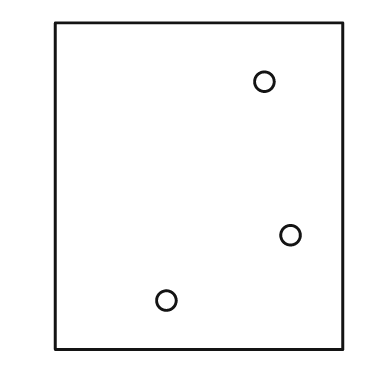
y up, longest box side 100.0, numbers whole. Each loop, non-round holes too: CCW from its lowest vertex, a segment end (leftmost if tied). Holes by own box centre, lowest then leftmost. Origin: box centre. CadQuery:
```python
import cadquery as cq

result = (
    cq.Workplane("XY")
    .moveTo(-44.0, -50.0)
    .lineTo(44.0, -50.0)
    .lineTo(44.0, 50.0)
    .lineTo(-44.0, 50.0)
    .close()
    .moveTo(-10.0, -35.0)
    .circle(3.0)
    .moveTo(28.0, -15.0)
    .circle(3.0)
    .moveTo(20.0, 32.0)
    .circle(3.0)
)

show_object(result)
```